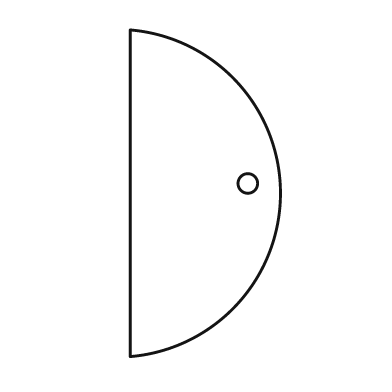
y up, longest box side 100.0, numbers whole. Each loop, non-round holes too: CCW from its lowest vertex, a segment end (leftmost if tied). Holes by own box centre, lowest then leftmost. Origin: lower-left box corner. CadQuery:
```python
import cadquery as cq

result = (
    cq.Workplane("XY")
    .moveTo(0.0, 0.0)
    .threePointArc((46.0, 50.0), (0.0, 100.0))
    .close()
    .moveTo(36.0, 53.0)
    .circle(3.0)
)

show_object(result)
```